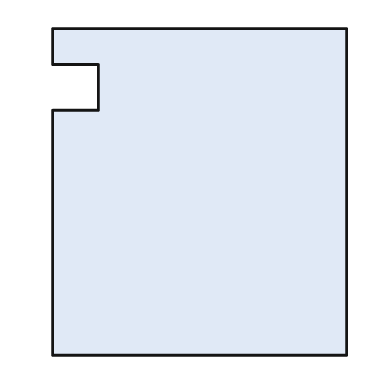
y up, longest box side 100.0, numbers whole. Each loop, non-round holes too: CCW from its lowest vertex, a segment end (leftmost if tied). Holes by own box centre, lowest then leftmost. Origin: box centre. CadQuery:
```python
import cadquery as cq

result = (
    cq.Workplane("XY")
    .moveTo(-45.0, -50.0)
    .lineTo(45.0, -50.0)
    .lineTo(45.0, 50.0)
    .lineTo(-45.0, 50.0)
    .lineTo(-45.0, 39.0)
    .lineTo(-31.0, 39.0)
    .lineTo(-31.0, 25.0)
    .lineTo(-45.0, 25.0)
    .close()
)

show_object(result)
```